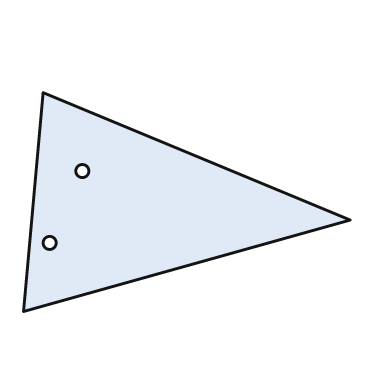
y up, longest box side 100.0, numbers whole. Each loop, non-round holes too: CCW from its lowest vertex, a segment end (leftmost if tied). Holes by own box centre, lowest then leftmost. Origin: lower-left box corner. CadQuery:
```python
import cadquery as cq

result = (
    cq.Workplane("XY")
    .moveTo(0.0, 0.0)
    .lineTo(100.0, 28.0)
    .lineTo(6.0, 67.0)
    .close()
    .moveTo(8.0, 21.0)
    .circle(2.0)
    .moveTo(18.0, 43.0)
    .circle(2.0)
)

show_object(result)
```